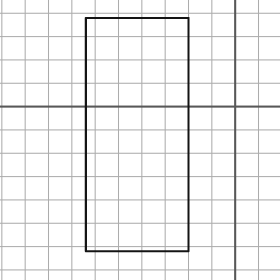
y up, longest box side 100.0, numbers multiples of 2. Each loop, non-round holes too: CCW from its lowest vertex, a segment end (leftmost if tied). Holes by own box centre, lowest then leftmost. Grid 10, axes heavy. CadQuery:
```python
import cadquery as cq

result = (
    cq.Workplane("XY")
    .moveTo(-64.0, -62.0)
    .lineTo(-20.0, -62.0)
    .lineTo(-20.0, 38.0)
    .lineTo(-64.0, 38.0)
    .close()
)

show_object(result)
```